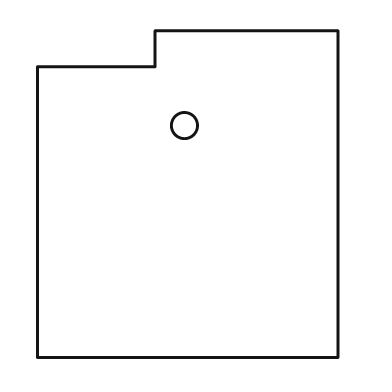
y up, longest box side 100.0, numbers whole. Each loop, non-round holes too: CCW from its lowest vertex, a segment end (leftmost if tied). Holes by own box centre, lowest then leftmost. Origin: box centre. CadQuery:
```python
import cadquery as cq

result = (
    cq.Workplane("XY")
    .moveTo(-46.0, -50.0)
    .lineTo(46.0, -50.0)
    .lineTo(46.0, 50.0)
    .lineTo(-10.0, 50.0)
    .lineTo(-10.0, 39.0)
    .lineTo(-46.0, 39.0)
    .close()
    .moveTo(-1.0, 21.0)
    .circle(4.0)
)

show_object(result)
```